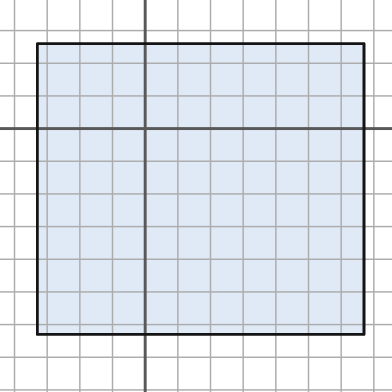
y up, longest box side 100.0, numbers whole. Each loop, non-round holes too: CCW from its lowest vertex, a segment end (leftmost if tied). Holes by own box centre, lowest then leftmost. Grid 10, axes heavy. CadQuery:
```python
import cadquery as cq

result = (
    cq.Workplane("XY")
    .moveTo(-33.0, -63.0)
    .lineTo(67.0, -63.0)
    .lineTo(67.0, 26.0)
    .lineTo(-33.0, 26.0)
    .close()
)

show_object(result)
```